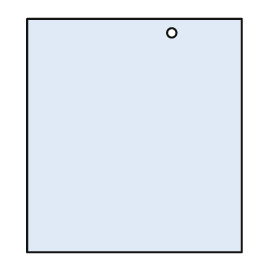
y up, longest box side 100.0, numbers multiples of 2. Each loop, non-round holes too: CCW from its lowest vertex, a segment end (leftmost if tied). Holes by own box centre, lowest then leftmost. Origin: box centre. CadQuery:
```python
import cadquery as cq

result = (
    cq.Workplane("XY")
    .moveTo(-46.0, -50.0)
    .lineTo(46.0, -50.0)
    .lineTo(46.0, 50.0)
    .lineTo(-46.0, 50.0)
    .close()
    .moveTo(16.0, 44.0)
    .circle(2.0)
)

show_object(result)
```